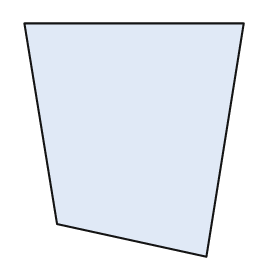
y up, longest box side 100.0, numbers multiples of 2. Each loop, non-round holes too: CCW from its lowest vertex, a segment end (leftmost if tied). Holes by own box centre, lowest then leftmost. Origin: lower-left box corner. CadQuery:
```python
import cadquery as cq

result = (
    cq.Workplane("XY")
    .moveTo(78.0, 0.0)
    .lineTo(94.0, 100.0)
    .lineTo(0.0, 100.0)
    .lineTo(14.0, 14.0)
    .close()
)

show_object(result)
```